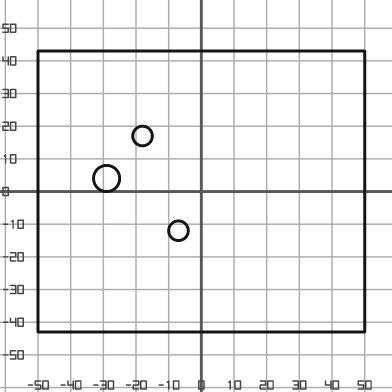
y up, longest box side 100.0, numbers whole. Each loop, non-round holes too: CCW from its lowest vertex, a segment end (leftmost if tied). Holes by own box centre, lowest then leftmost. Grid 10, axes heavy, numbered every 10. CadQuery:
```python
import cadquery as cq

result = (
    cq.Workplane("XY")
    .moveTo(-50.0, -43.0)
    .lineTo(50.0, -43.0)
    .lineTo(50.0, 43.0)
    .lineTo(-50.0, 43.0)
    .close()
    .moveTo(-7.0, -12.0)
    .circle(3.0)
    .moveTo(-29.0, 4.0)
    .circle(4.0)
    .moveTo(-18.0, 17.0)
    .circle(3.0)
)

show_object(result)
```